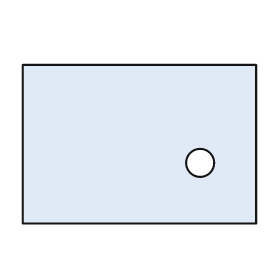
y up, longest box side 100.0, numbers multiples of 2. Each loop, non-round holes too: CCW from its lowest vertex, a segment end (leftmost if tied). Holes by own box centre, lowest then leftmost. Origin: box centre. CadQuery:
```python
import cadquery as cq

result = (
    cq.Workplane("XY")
    .moveTo(-50.0, -34.0)
    .lineTo(50.0, -34.0)
    .lineTo(50.0, 34.0)
    .lineTo(-50.0, 34.0)
    .close()
    .moveTo(26.0, -8.0)
    .circle(6.0)
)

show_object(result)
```